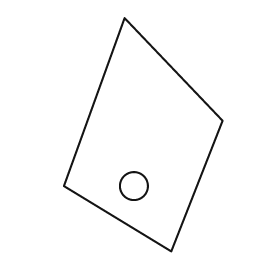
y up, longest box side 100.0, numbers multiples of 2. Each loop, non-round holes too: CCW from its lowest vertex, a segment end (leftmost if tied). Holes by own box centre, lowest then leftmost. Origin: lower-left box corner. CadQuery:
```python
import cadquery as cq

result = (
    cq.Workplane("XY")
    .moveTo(46.0, 0.0)
    .lineTo(68.0, 56.0)
    .lineTo(26.0, 100.0)
    .lineTo(0.0, 28.0)
    .close()
    .moveTo(30.0, 28.0)
    .circle(6.0)
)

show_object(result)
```